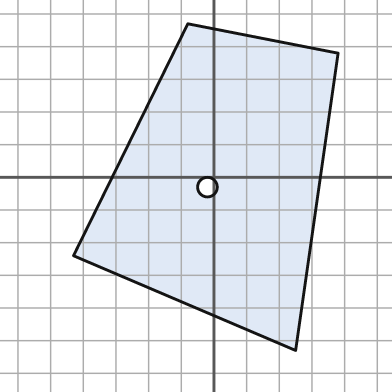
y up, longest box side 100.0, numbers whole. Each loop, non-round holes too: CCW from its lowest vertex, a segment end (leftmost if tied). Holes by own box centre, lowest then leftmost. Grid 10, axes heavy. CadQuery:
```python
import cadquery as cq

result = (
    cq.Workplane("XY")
    .moveTo(25.0, -53.0)
    .lineTo(38.0, 38.0)
    .lineTo(-8.0, 47.0)
    .lineTo(-43.0, -24.0)
    .close()
    .moveTo(-2.0, -3.0)
    .circle(3.0)
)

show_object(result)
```